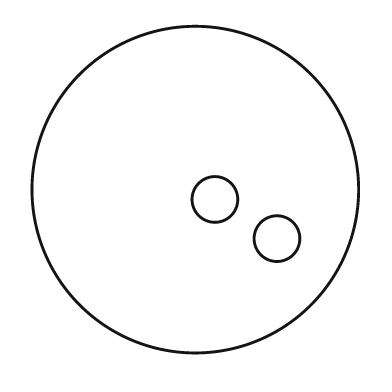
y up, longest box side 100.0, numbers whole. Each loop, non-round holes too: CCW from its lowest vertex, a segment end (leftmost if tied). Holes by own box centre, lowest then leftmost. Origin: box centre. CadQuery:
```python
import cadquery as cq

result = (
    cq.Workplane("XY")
    .moveTo(0.0, 0.0)
    .circle(50.0)
    .moveTo(25.0, -15.0)
    .circle(7.0)
    .moveTo(6.0, -3.0)
    .circle(7.0)
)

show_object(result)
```